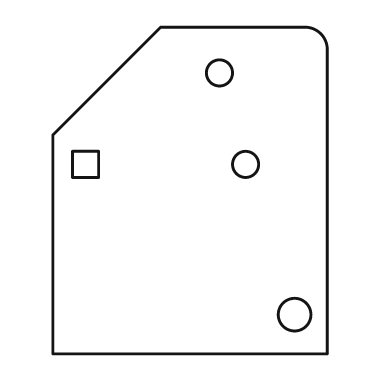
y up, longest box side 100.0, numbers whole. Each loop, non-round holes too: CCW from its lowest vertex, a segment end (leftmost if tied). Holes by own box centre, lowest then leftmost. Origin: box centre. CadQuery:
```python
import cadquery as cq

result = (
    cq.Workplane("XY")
    .moveTo(-42.0, -50.0)
    .lineTo(42.0, -50.0)
    .lineTo(42.0, 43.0)
    .threePointArc((40.0, 48.0), (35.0, 50.0))
    .lineTo(-9.0, 50.0)
    .lineTo(-42.0, 17.0)
    .close()
    .moveTo(32.0, -38.0)
    .circle(5.0)
    .moveTo(-36.0, 4.0)
    .lineTo(-28.0, 4.0)
    .lineTo(-28.0, 12.0)
    .lineTo(-36.0, 12.0)
    .close()
    .moveTo(17.0, 8.0)
    .circle(4.0)
    .moveTo(9.0, 36.0)
    .circle(4.0)
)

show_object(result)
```